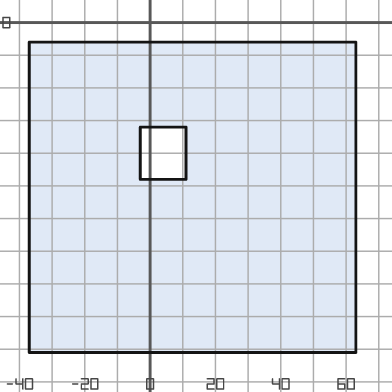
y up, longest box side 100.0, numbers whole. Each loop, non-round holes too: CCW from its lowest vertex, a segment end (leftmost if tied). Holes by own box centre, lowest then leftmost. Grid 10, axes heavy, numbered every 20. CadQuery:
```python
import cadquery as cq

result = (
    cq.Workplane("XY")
    .moveTo(-37.0, -101.0)
    .lineTo(63.0, -101.0)
    .lineTo(63.0, -6.0)
    .lineTo(-37.0, -6.0)
    .close()
    .moveTo(-3.0, -48.0)
    .lineTo(11.0, -48.0)
    .lineTo(11.0, -32.0)
    .lineTo(-3.0, -32.0)
    .close()
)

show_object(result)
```